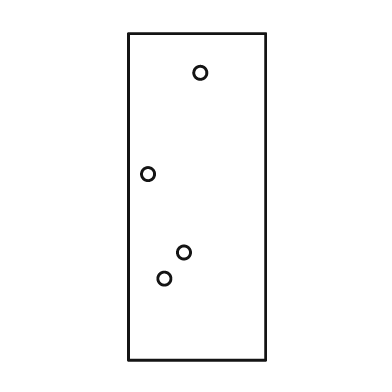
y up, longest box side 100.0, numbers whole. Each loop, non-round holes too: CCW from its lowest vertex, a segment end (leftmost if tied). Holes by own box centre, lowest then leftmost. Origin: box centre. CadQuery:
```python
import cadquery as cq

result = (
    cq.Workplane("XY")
    .moveTo(-21.0, -50.0)
    .lineTo(21.0, -50.0)
    .lineTo(21.0, 50.0)
    .lineTo(-21.0, 50.0)
    .close()
    .moveTo(-10.0, -25.0)
    .circle(2.0)
    .moveTo(-4.0, -17.0)
    .circle(2.0)
    .moveTo(-15.0, 7.0)
    .circle(2.0)
    .moveTo(1.0, 38.0)
    .circle(2.0)
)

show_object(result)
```